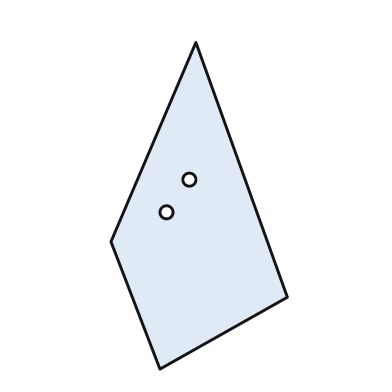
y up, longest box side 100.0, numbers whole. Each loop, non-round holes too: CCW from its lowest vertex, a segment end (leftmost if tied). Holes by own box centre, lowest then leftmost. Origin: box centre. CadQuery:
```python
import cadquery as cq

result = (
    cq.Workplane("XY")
    .moveTo(-12.0, -50.0)
    .lineTo(27.0, -28.0)
    .lineTo(-1.0, 50.0)
    .lineTo(-27.0, -11.0)
    .close()
    .moveTo(-10.0, -2.0)
    .circle(2.0)
    .moveTo(-3.0, 8.0)
    .circle(2.0)
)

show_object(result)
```